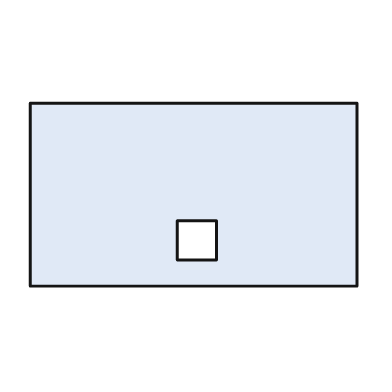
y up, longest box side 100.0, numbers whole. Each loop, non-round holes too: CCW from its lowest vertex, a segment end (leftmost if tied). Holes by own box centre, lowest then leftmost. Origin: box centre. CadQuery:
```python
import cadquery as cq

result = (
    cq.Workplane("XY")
    .moveTo(-50.0, -28.0)
    .lineTo(50.0, -28.0)
    .lineTo(50.0, 28.0)
    .lineTo(-50.0, 28.0)
    .close()
    .moveTo(-5.0, -20.0)
    .lineTo(7.0, -20.0)
    .lineTo(7.0, -8.0)
    .lineTo(-5.0, -8.0)
    .close()
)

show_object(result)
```